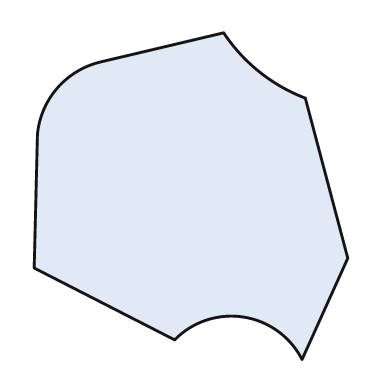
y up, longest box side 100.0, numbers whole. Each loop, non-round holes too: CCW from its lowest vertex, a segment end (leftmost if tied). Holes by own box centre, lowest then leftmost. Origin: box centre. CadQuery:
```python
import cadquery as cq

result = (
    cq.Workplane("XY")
    .moveTo(34.0, -50.0)
    .lineTo(48.0, -19.0)
    .lineTo(35.0, 30.0)
    .threePointArc((21.0, 38.0), (10.0, 50.0))
    .lineTo(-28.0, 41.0)
    .threePointArc((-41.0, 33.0), (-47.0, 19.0))
    .lineTo(-48.0, -22.0)
    .lineTo(-5.0, -44.0)
    .threePointArc((16.0, -37.0), (34.0, -50.0))
    .close()
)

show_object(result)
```